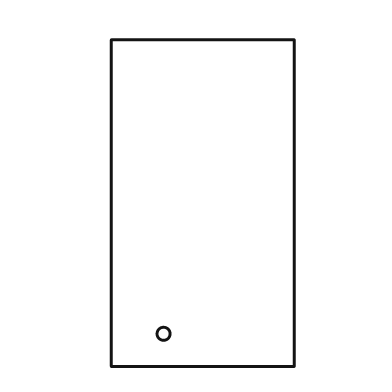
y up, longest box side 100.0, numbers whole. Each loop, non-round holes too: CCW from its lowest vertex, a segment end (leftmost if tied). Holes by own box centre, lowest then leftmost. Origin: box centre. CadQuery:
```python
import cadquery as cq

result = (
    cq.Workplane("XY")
    .moveTo(-28.0, -50.0)
    .lineTo(28.0, -50.0)
    .lineTo(28.0, 50.0)
    .lineTo(-28.0, 50.0)
    .close()
    .moveTo(-12.0, -40.0)
    .circle(2.0)
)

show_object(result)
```